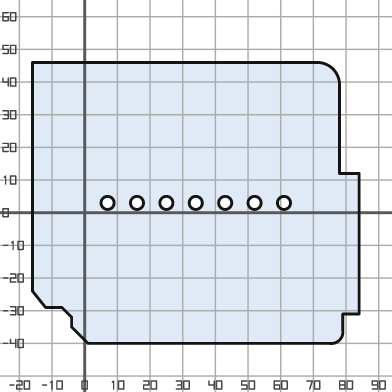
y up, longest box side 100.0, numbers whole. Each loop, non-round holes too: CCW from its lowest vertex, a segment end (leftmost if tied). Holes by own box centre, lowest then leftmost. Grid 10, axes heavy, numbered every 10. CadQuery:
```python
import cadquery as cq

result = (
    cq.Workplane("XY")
    .moveTo(1.0, -40.0)
    .lineTo(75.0, -40.0)
    .threePointArc((78.0, -39.0), (79.0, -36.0))
    .lineTo(79.0, -31.0)
    .lineTo(84.0, -31.0)
    .lineTo(84.0, 12.0)
    .lineTo(78.0, 12.0)
    .lineTo(78.0, 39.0)
    .threePointArc((76.0, 44.0), (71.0, 46.0))
    .lineTo(-16.0, 46.0)
    .lineTo(-16.0, -24.0)
    .lineTo(-12.0, -29.0)
    .lineTo(-7.0, -29.0)
    .lineTo(-4.0, -32.0)
    .lineTo(-4.0, -35.0)
    .close()
    .moveTo(7.0, 3.0)
    .circle(2.0)
    .moveTo(16.0, 3.0)
    .circle(2.0)
    .moveTo(25.0, 3.0)
    .circle(2.0)
    .moveTo(34.0, 3.0)
    .circle(2.0)
    .moveTo(43.0, 3.0)
    .circle(2.0)
    .moveTo(52.0, 3.0)
    .circle(2.0)
    .moveTo(61.0, 3.0)
    .circle(2.0)
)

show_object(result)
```